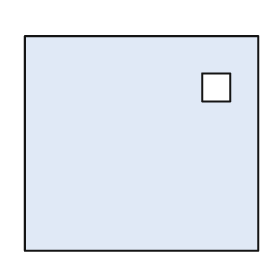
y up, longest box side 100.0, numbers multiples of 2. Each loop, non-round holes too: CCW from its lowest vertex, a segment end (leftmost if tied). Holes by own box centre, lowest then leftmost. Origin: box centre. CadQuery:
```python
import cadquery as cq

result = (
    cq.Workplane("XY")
    .moveTo(-50.0, -46.0)
    .lineTo(50.0, -46.0)
    .lineTo(50.0, 46.0)
    .lineTo(-50.0, 46.0)
    .close()
    .moveTo(26.0, 18.0)
    .lineTo(38.0, 18.0)
    .lineTo(38.0, 30.0)
    .lineTo(26.0, 30.0)
    .close()
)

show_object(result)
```